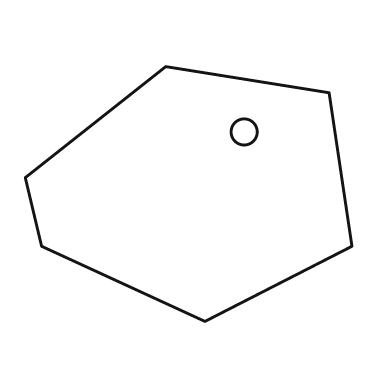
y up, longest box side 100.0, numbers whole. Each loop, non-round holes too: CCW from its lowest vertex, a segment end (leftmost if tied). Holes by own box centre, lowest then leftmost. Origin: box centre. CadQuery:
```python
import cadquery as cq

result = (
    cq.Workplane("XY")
    .moveTo(5.0, -39.0)
    .lineTo(50.0, -16.0)
    .lineTo(43.0, 31.0)
    .lineTo(-7.0, 39.0)
    .lineTo(-50.0, 5.0)
    .lineTo(-45.0, -16.0)
    .close()
    .moveTo(17.0, 19.0)
    .circle(4.0)
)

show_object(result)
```